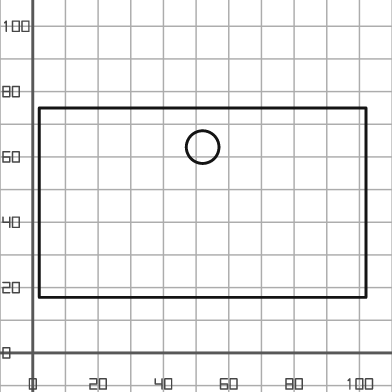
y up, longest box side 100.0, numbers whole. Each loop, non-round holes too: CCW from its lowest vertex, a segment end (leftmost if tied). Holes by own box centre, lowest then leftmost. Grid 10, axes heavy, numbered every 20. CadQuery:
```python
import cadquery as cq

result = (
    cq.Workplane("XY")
    .moveTo(2.0, 17.0)
    .lineTo(102.0, 17.0)
    .lineTo(102.0, 75.0)
    .lineTo(2.0, 75.0)
    .close()
    .moveTo(52.0, 63.0)
    .circle(5.0)
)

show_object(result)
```